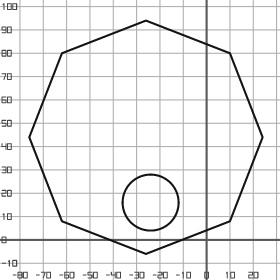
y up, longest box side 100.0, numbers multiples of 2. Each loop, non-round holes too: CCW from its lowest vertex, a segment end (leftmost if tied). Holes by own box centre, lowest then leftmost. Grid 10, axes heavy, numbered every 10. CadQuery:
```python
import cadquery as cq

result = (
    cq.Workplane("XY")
    .moveTo(-26.0, -6.0)
    .lineTo(10.0, 8.0)
    .lineTo(24.0, 44.0)
    .lineTo(10.0, 80.0)
    .lineTo(-26.0, 94.0)
    .lineTo(-62.0, 80.0)
    .lineTo(-76.0, 44.0)
    .lineTo(-62.0, 8.0)
    .close()
    .moveTo(-24.0, 16.0)
    .circle(12.0)
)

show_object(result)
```